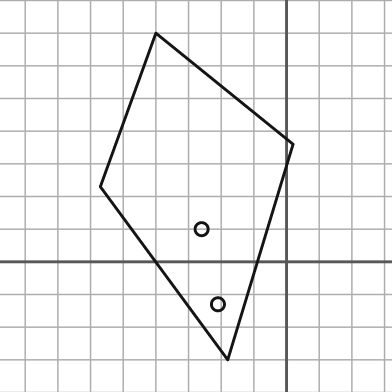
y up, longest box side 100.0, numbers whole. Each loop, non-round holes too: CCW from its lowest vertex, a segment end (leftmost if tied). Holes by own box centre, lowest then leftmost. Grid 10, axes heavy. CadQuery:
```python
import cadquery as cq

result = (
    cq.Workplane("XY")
    .moveTo(-18.0, -30.0)
    .lineTo(2.0, 36.0)
    .lineTo(-40.0, 70.0)
    .lineTo(-57.0, 23.0)
    .close()
    .moveTo(-21.0, -13.0)
    .circle(2.0)
    .moveTo(-26.0, 10.0)
    .circle(2.0)
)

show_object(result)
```